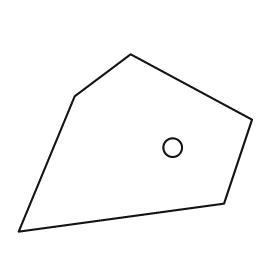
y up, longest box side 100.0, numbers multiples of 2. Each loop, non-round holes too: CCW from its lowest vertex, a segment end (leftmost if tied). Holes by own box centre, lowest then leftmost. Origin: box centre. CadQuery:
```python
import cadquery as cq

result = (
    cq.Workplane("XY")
    .moveTo(-50.0, -38.0)
    .lineTo(38.0, -26.0)
    .lineTo(50.0, 10.0)
    .lineTo(-2.0, 38.0)
    .lineTo(-26.0, 20.0)
    .close()
    .moveTo(16.0, -2.0)
    .circle(4.0)
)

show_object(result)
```